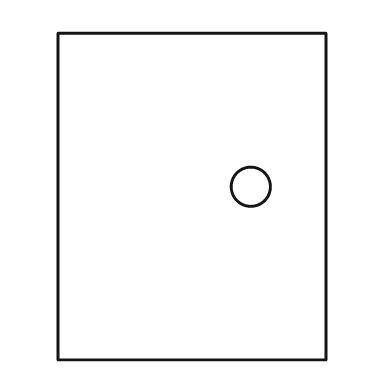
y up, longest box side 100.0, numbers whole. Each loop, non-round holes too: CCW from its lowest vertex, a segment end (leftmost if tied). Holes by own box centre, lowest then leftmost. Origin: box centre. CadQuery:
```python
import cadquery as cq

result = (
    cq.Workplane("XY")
    .moveTo(-41.0, -50.0)
    .lineTo(41.0, -50.0)
    .lineTo(41.0, 50.0)
    .lineTo(-41.0, 50.0)
    .close()
    .moveTo(18.0, 3.0)
    .circle(6.0)
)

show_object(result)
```